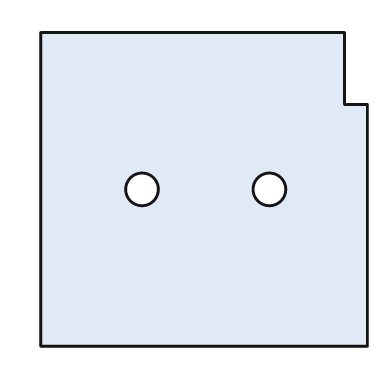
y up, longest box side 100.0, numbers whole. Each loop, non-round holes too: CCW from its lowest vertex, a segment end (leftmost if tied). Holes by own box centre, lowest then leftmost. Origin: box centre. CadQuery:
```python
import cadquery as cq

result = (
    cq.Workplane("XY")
    .moveTo(-50.0, -48.0)
    .lineTo(50.0, -48.0)
    .lineTo(50.0, 26.0)
    .lineTo(43.0, 26.0)
    .lineTo(43.0, 48.0)
    .lineTo(-50.0, 48.0)
    .close()
    .moveTo(-19.0, 0.0)
    .circle(5.0)
    .moveTo(20.0, 0.0)
    .circle(5.0)
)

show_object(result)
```